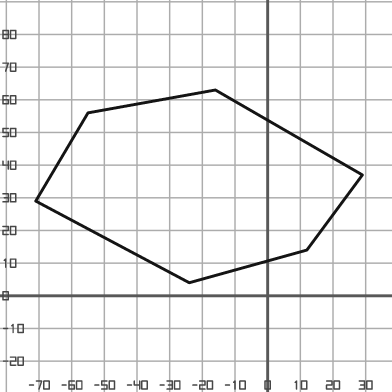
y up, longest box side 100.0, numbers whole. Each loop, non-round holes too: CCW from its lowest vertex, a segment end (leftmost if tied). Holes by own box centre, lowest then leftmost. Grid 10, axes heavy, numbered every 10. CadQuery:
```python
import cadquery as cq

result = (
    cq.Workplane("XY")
    .moveTo(-24.0, 4.0)
    .lineTo(12.0, 14.0)
    .lineTo(29.0, 37.0)
    .lineTo(-16.0, 63.0)
    .lineTo(-55.0, 56.0)
    .lineTo(-71.0, 29.0)
    .close()
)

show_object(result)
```